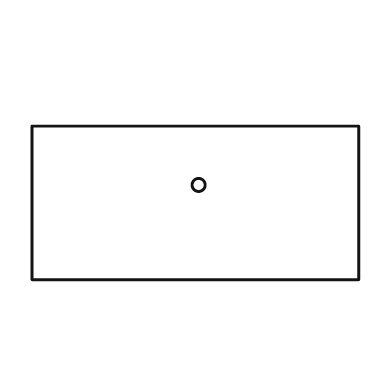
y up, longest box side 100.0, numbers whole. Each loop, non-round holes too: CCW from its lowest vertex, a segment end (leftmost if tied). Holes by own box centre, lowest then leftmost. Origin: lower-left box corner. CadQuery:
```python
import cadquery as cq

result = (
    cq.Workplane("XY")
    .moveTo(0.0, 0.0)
    .lineTo(100.0, 0.0)
    .lineTo(100.0, 47.0)
    .lineTo(0.0, 47.0)
    .close()
    .moveTo(51.0, 29.0)
    .circle(2.0)
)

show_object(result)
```